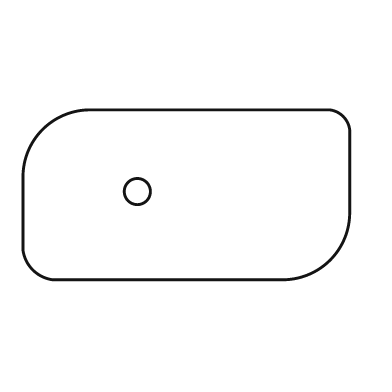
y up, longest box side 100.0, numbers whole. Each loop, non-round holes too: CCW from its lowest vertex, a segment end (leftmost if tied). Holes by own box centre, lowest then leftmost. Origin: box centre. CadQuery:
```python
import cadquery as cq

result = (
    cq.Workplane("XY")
    .moveTo(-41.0, -26.0)
    .lineTo(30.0, -26.0)
    .threePointArc((44.0, -20.0), (50.0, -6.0))
    .lineTo(50.0, 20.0)
    .threePointArc((48.0, 24.0), (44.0, 26.0))
    .lineTo(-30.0, 26.0)
    .threePointArc((-44.0, 20.0), (-50.0, 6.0))
    .lineTo(-50.0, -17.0)
    .threePointArc((-47.0, -23.0), (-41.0, -26.0))
    .close()
    .moveTo(-15.0, 1.0)
    .circle(4.0)
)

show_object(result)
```